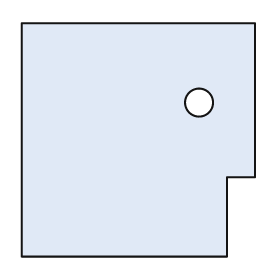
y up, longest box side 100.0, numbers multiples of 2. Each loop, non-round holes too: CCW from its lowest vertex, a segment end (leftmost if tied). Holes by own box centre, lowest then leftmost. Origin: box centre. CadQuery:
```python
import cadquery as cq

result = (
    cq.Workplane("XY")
    .moveTo(-50.0, -50.0)
    .lineTo(38.0, -50.0)
    .lineTo(38.0, -16.0)
    .lineTo(50.0, -16.0)
    .lineTo(50.0, 50.0)
    .lineTo(-50.0, 50.0)
    .close()
    .moveTo(26.0, 16.0)
    .circle(6.0)
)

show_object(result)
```